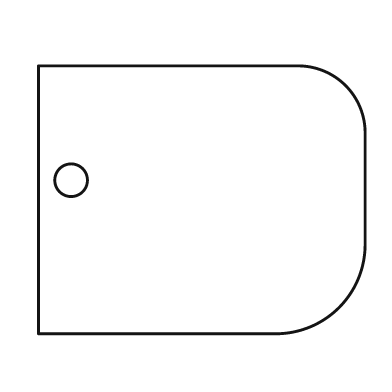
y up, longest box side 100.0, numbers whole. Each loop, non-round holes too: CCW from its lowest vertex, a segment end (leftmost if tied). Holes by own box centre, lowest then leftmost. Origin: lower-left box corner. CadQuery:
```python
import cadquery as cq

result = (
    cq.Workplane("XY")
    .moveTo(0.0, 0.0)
    .lineTo(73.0, 0.0)
    .threePointArc((92.0, 8.0), (100.0, 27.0))
    .lineTo(100.0, 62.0)
    .threePointArc((94.0, 76.0), (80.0, 82.0))
    .lineTo(0.0, 82.0)
    .close()
    .moveTo(10.0, 47.0)
    .circle(5.0)
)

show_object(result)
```